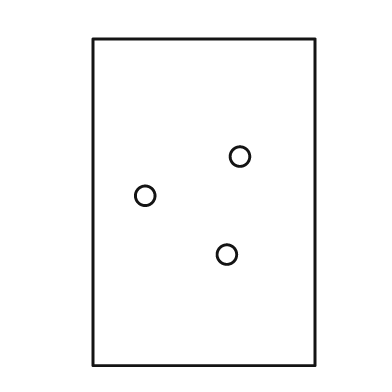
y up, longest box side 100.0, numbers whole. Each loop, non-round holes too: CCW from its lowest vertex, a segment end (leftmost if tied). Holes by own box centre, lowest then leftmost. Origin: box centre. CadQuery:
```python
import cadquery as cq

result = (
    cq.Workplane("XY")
    .moveTo(-34.0, -50.0)
    .lineTo(34.0, -50.0)
    .lineTo(34.0, 50.0)
    .lineTo(-34.0, 50.0)
    .close()
    .moveTo(7.0, -16.0)
    .circle(3.0)
    .moveTo(-18.0, 2.0)
    .circle(3.0)
    .moveTo(11.0, 14.0)
    .circle(3.0)
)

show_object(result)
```